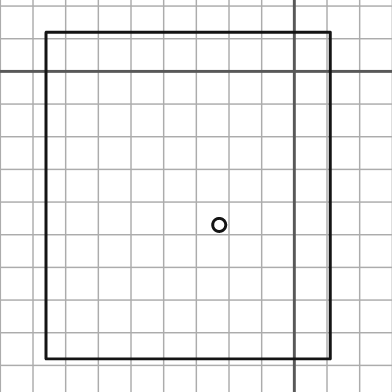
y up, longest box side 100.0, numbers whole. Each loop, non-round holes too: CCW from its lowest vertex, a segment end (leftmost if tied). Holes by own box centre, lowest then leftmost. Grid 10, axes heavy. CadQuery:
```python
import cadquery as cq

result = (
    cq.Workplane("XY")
    .moveTo(-76.0, -88.0)
    .lineTo(11.0, -88.0)
    .lineTo(11.0, 12.0)
    .lineTo(-76.0, 12.0)
    .close()
    .moveTo(-23.0, -47.0)
    .circle(2.0)
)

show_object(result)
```